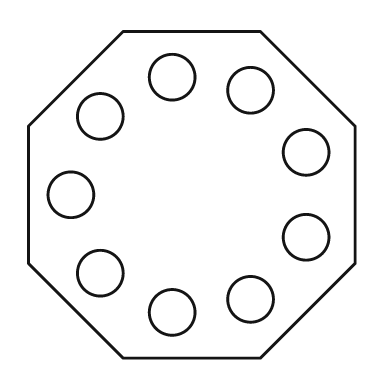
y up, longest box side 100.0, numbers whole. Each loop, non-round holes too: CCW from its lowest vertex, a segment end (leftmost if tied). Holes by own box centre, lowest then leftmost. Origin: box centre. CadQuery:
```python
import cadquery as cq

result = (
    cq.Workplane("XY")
    .moveTo(-21.0, -50.0)
    .lineTo(21.0, -50.0)
    .lineTo(50.0, -21.0)
    .lineTo(50.0, 21.0)
    .lineTo(21.0, 50.0)
    .lineTo(-21.0, 50.0)
    .lineTo(-50.0, 21.0)
    .lineTo(-50.0, -21.0)
    .close()
    .moveTo(-6.0, -36.0)
    .circle(7.0)
    .moveTo(18.0, -32.0)
    .circle(7.0)
    .moveTo(-28.0, -24.0)
    .circle(7.0)
    .moveTo(35.0, -13.0)
    .circle(7.0)
    .moveTo(-37.0, 0.0)
    .circle(7.0)
    .moveTo(35.0, 13.0)
    .circle(7.0)
    .moveTo(-28.0, 24.0)
    .circle(7.0)
    .moveTo(18.0, 32.0)
    .circle(7.0)
    .moveTo(-6.0, 36.0)
    .circle(7.0)
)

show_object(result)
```